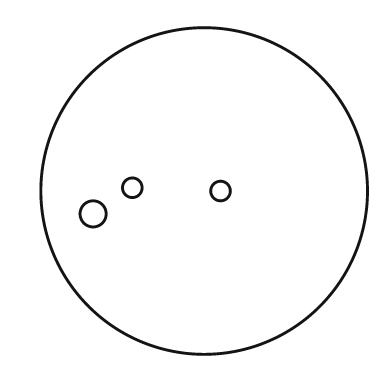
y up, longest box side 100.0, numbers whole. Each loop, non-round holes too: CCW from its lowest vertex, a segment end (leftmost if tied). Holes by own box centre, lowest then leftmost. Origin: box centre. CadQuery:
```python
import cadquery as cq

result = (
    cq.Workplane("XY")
    .moveTo(0.0, 0.0)
    .circle(50.0)
    .moveTo(-34.0, -7.0)
    .circle(4.0)
    .moveTo(5.0, 0.0)
    .circle(3.0)
    .moveTo(-22.0, 1.0)
    .circle(3.0)
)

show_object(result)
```